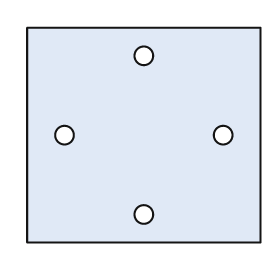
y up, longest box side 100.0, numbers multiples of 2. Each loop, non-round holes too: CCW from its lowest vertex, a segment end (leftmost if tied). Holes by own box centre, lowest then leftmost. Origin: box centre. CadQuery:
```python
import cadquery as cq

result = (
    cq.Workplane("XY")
    .moveTo(-50.0, -46.0)
    .lineTo(50.0, -46.0)
    .lineTo(50.0, 46.0)
    .lineTo(-50.0, 46.0)
    .close()
    .moveTo(0.0, -34.0)
    .circle(4.0)
    .moveTo(-34.0, 0.0)
    .circle(4.0)
    .moveTo(34.0, 0.0)
    .circle(4.0)
    .moveTo(0.0, 34.0)
    .circle(4.0)
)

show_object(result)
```